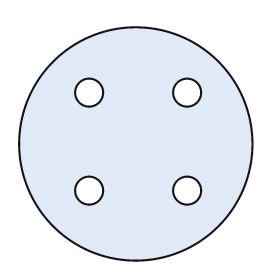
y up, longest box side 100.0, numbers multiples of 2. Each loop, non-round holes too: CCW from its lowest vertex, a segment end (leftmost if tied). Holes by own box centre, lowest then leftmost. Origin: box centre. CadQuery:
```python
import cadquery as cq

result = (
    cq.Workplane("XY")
    .moveTo(0.0, 0.0)
    .circle(50.0)
    .moveTo(-20.0, -20.0)
    .circle(6.0)
    .moveTo(22.0, -20.0)
    .circle(6.0)
    .moveTo(-20.0, 22.0)
    .circle(6.0)
    .moveTo(22.0, 22.0)
    .circle(6.0)
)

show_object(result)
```